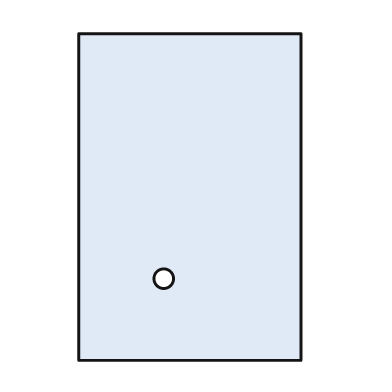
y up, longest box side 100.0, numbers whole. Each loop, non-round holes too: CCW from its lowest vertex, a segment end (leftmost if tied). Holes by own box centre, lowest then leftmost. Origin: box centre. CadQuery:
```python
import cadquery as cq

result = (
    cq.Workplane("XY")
    .moveTo(-34.0, -50.0)
    .lineTo(34.0, -50.0)
    .lineTo(34.0, 50.0)
    .lineTo(-34.0, 50.0)
    .close()
    .moveTo(-8.0, -25.0)
    .circle(3.0)
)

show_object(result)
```